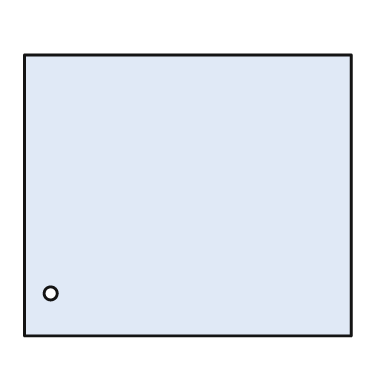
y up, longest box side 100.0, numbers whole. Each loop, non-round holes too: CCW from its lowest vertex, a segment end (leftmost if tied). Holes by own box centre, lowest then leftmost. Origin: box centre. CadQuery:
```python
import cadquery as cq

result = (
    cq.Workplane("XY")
    .moveTo(-50.0, -43.0)
    .lineTo(50.0, -43.0)
    .lineTo(50.0, 43.0)
    .lineTo(-50.0, 43.0)
    .close()
    .moveTo(-42.0, -30.0)
    .circle(2.0)
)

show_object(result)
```